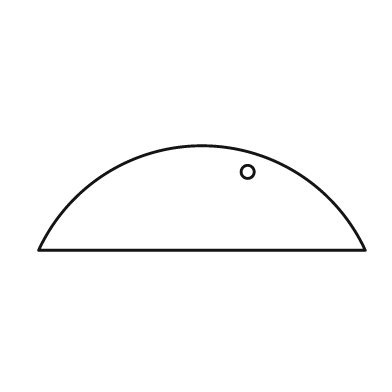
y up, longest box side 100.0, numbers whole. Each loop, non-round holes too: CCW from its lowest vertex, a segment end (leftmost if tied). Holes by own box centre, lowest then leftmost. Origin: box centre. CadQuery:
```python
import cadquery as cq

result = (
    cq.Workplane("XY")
    .moveTo(-50.0, -16.0)
    .lineTo(50.0, -16.0)
    .threePointArc((0.0, 16.0), (-50.0, -16.0))
    .close()
    .moveTo(14.0, 8.0)
    .circle(2.0)
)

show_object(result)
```